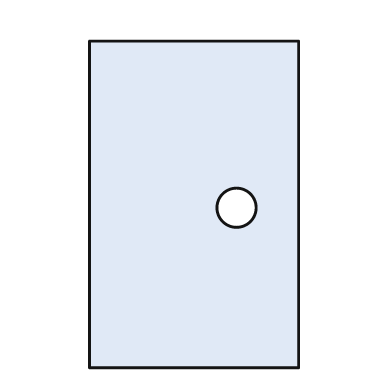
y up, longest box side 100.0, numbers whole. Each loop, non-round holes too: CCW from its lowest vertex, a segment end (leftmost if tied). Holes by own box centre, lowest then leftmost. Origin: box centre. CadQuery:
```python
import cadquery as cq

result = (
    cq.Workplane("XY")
    .moveTo(-32.0, -50.0)
    .lineTo(32.0, -50.0)
    .lineTo(32.0, 50.0)
    .lineTo(-32.0, 50.0)
    .close()
    .moveTo(13.0, -1.0)
    .circle(6.0)
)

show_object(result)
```